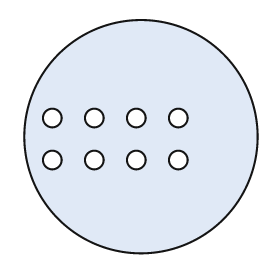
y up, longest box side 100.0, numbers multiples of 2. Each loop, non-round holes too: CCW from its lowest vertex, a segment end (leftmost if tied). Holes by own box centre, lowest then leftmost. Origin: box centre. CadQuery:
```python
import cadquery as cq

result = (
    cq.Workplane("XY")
    .moveTo(0.0, 0.0)
    .circle(50.0)
    .moveTo(-38.0, -10.0)
    .circle(4.0)
    .moveTo(-20.0, -10.0)
    .circle(4.0)
    .moveTo(-2.0, -10.0)
    .circle(4.0)
    .moveTo(16.0, -10.0)
    .circle(4.0)
    .moveTo(-38.0, 8.0)
    .circle(4.0)
    .moveTo(-20.0, 8.0)
    .circle(4.0)
    .moveTo(-2.0, 8.0)
    .circle(4.0)
    .moveTo(16.0, 8.0)
    .circle(4.0)
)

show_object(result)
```